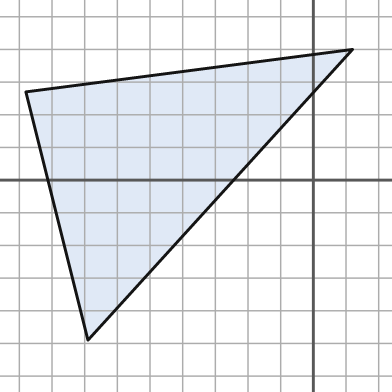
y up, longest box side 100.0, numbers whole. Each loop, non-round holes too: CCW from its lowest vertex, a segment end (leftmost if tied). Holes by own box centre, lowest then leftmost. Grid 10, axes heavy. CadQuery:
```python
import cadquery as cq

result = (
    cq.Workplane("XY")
    .moveTo(-69.0, -49.0)
    .lineTo(12.0, 40.0)
    .lineTo(-88.0, 27.0)
    .close()
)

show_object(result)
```